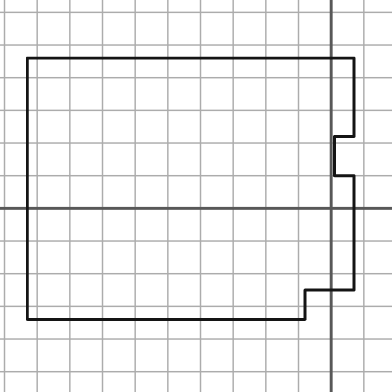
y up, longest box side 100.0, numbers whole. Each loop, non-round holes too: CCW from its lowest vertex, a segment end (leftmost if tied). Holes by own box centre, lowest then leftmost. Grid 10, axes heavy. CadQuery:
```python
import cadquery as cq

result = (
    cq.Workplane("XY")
    .moveTo(-93.0, -34.0)
    .lineTo(-8.0, -34.0)
    .lineTo(-8.0, -25.0)
    .lineTo(7.0, -25.0)
    .lineTo(7.0, 10.0)
    .lineTo(1.0, 10.0)
    .lineTo(1.0, 22.0)
    .lineTo(7.0, 22.0)
    .lineTo(7.0, 46.0)
    .lineTo(-93.0, 46.0)
    .close()
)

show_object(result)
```